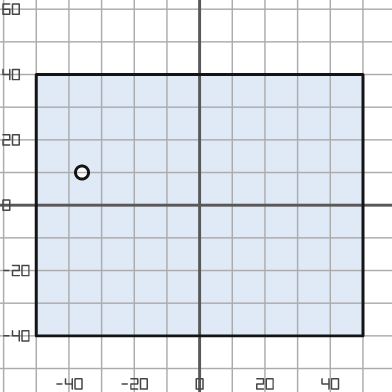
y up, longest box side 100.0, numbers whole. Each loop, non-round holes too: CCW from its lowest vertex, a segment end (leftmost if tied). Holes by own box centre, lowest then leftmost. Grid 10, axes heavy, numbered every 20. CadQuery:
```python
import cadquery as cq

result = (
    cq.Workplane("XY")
    .moveTo(-50.0, -40.0)
    .lineTo(50.0, -40.0)
    .lineTo(50.0, 40.0)
    .lineTo(-50.0, 40.0)
    .close()
    .moveTo(-36.0, 10.0)
    .circle(2.0)
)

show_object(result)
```